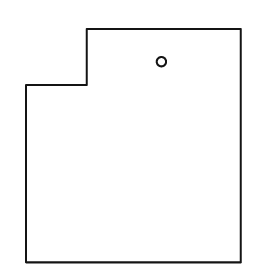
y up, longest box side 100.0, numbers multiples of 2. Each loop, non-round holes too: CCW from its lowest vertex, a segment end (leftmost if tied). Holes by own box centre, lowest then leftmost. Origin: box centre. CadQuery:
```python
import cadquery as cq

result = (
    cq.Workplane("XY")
    .moveTo(-46.0, -50.0)
    .lineTo(46.0, -50.0)
    .lineTo(46.0, 50.0)
    .lineTo(-20.0, 50.0)
    .lineTo(-20.0, 26.0)
    .lineTo(-46.0, 26.0)
    .close()
    .moveTo(12.0, 36.0)
    .circle(2.0)
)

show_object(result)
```